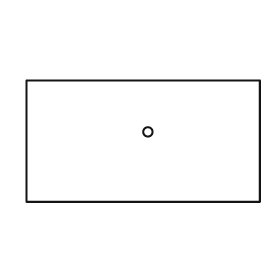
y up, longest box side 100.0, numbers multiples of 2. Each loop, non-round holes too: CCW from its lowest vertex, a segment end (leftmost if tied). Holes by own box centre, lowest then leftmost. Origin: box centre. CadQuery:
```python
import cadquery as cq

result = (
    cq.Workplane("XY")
    .moveTo(-50.0, -26.0)
    .lineTo(50.0, -26.0)
    .lineTo(50.0, 26.0)
    .lineTo(-50.0, 26.0)
    .close()
    .moveTo(2.0, 4.0)
    .circle(2.0)
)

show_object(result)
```